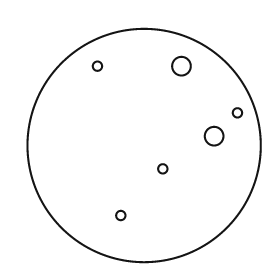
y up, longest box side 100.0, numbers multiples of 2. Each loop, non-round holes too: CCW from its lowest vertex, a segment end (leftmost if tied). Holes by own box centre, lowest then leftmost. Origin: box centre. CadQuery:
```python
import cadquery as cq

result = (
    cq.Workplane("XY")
    .moveTo(0.0, 0.0)
    .circle(50.0)
    .moveTo(-10.0, -30.0)
    .circle(2.0)
    .moveTo(8.0, -10.0)
    .circle(2.0)
    .moveTo(30.0, 4.0)
    .circle(4.0)
    .moveTo(40.0, 14.0)
    .circle(2.0)
    .moveTo(-20.0, 34.0)
    .circle(2.0)
    .moveTo(16.0, 34.0)
    .circle(4.0)
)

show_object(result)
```